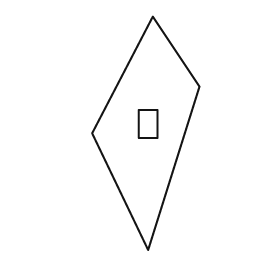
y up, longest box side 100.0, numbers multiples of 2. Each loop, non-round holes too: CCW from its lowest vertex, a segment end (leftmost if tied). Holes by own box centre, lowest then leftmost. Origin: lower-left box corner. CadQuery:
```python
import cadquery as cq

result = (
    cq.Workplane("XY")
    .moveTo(24.0, 0.0)
    .lineTo(46.0, 70.0)
    .lineTo(26.0, 100.0)
    .lineTo(0.0, 50.0)
    .close()
    .moveTo(20.0, 48.0)
    .lineTo(28.0, 48.0)
    .lineTo(28.0, 60.0)
    .lineTo(20.0, 60.0)
    .close()
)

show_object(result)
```